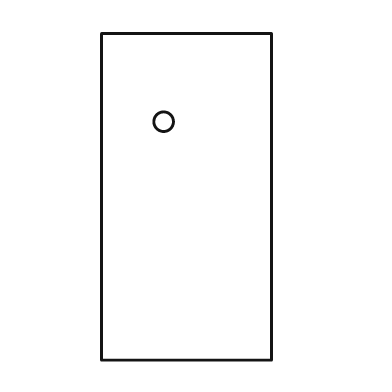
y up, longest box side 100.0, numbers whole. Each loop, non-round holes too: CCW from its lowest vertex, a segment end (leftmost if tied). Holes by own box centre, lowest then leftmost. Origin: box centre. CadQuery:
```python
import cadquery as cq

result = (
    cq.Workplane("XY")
    .moveTo(-26.0, -50.0)
    .lineTo(26.0, -50.0)
    .lineTo(26.0, 50.0)
    .lineTo(-26.0, 50.0)
    .close()
    .moveTo(-7.0, 23.0)
    .circle(3.0)
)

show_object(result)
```